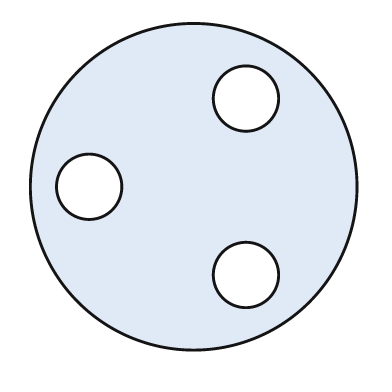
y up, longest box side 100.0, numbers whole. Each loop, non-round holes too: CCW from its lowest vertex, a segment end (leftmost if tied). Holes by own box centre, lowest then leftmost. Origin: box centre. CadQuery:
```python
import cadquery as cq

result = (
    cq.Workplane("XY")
    .moveTo(0.0, 0.0)
    .circle(50.0)
    .moveTo(16.0, -27.0)
    .circle(10.0)
    .moveTo(-32.0, 0.0)
    .circle(10.0)
    .moveTo(16.0, 27.0)
    .circle(10.0)
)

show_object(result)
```